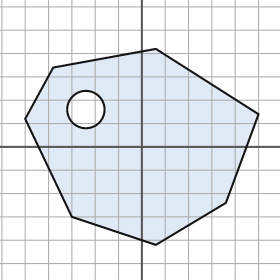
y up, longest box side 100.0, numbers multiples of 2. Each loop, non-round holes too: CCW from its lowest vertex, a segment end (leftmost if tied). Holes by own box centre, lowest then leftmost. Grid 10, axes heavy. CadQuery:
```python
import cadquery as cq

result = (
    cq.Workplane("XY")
    .moveTo(6.0, -42.0)
    .lineTo(36.0, -24.0)
    .lineTo(50.0, 14.0)
    .lineTo(6.0, 42.0)
    .lineTo(-38.0, 34.0)
    .lineTo(-50.0, 12.0)
    .lineTo(-30.0, -30.0)
    .close()
    .moveTo(-24.0, 16.0)
    .circle(8.0)
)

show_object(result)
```